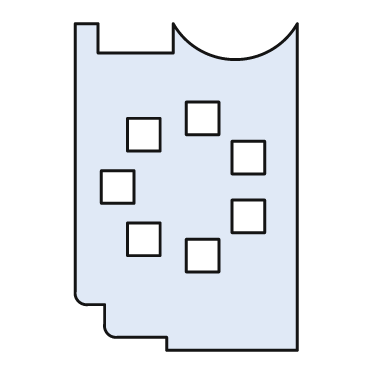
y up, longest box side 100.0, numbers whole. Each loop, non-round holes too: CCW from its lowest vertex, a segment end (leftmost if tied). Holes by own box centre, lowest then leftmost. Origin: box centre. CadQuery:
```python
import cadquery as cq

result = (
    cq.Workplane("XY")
    .moveTo(-6.0, -50.0)
    .lineTo(34.0, -50.0)
    .lineTo(34.0, 50.0)
    .threePointArc((15.0, 39.0), (-4.0, 50.0))
    .lineTo(-4.0, 41.0)
    .lineTo(-27.0, 41.0)
    .lineTo(-27.0, 50.0)
    .lineTo(-34.0, 50.0)
    .lineTo(-34.0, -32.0)
    .threePointArc((-33.0, -35.0), (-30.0, -36.0))
    .lineTo(-25.0, -36.0)
    .lineTo(-25.0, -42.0)
    .threePointArc((-24.0, -45.0), (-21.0, -46.0))
    .lineTo(-6.0, -46.0)
    .close()
    .moveTo(0.0, -26.0)
    .lineTo(10.0, -26.0)
    .lineTo(10.0, -16.0)
    .lineTo(0.0, -16.0)
    .close()
    .moveTo(-18.0, -21.0)
    .lineTo(-8.0, -21.0)
    .lineTo(-8.0, -11.0)
    .lineTo(-18.0, -11.0)
    .close()
    .moveTo(14.0, -14.0)
    .lineTo(24.0, -14.0)
    .lineTo(24.0, -4.0)
    .lineTo(14.0, -4.0)
    .close()
    .moveTo(-26.0, -5.0)
    .lineTo(-16.0, -5.0)
    .lineTo(-16.0, 5.0)
    .lineTo(-26.0, 5.0)
    .close()
    .moveTo(14.0, 4.0)
    .lineTo(24.0, 4.0)
    .lineTo(24.0, 14.0)
    .lineTo(14.0, 14.0)
    .close()
    .moveTo(-18.0, 11.0)
    .lineTo(-8.0, 11.0)
    .lineTo(-8.0, 21.0)
    .lineTo(-18.0, 21.0)
    .close()
    .moveTo(0.0, 16.0)
    .lineTo(10.0, 16.0)
    .lineTo(10.0, 26.0)
    .lineTo(0.0, 26.0)
    .close()
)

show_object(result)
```